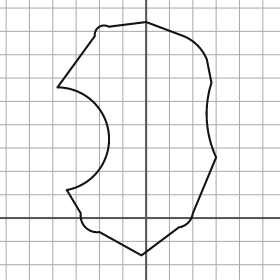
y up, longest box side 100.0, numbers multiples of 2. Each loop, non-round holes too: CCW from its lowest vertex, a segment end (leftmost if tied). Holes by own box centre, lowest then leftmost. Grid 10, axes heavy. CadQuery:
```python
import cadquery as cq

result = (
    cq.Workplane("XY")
    .moveTo(-2.0, -16.0)
    .lineTo(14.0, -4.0)
    .threePointArc((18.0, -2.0), (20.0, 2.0))
    .lineTo(30.0, 26.0)
    .threePointArc((26.0, 42.0), (28.0, 58.0))
    .lineTo(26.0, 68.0)
    .threePointArc((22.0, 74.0), (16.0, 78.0))
    .lineTo(0.0, 84.0)
    .lineTo(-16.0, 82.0)
    .threePointArc((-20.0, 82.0), (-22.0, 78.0))
    .lineTo(-38.0, 56.0)
    .threePointArc((-16.0, 36.0), (-34.0, 12.0))
    .lineTo(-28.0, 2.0)
    .threePointArc((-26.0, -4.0), (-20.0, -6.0))
    .close()
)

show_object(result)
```